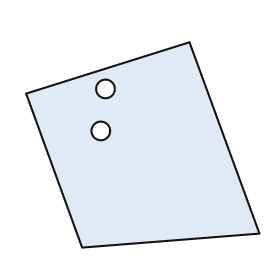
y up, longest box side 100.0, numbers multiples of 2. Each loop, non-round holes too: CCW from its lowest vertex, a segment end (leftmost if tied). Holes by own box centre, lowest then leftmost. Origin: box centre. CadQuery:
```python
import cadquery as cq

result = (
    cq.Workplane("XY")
    .moveTo(-26.0, -44.0)
    .lineTo(50.0, -38.0)
    .lineTo(20.0, 44.0)
    .lineTo(-50.0, 22.0)
    .close()
    .moveTo(-18.0, 6.0)
    .circle(4.0)
    .moveTo(-16.0, 24.0)
    .circle(4.0)
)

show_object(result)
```